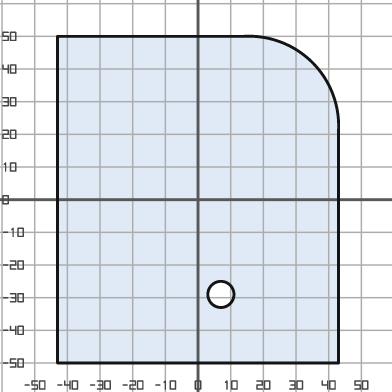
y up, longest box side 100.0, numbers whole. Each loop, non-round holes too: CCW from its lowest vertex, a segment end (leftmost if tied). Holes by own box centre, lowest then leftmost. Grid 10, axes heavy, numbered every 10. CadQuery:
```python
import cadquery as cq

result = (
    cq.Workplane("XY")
    .moveTo(-43.0, -50.0)
    .lineTo(43.0, -50.0)
    .lineTo(43.0, 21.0)
    .threePointArc((35.0, 42.0), (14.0, 50.0))
    .lineTo(-43.0, 50.0)
    .close()
    .moveTo(7.0, -29.0)
    .circle(4.0)
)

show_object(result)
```